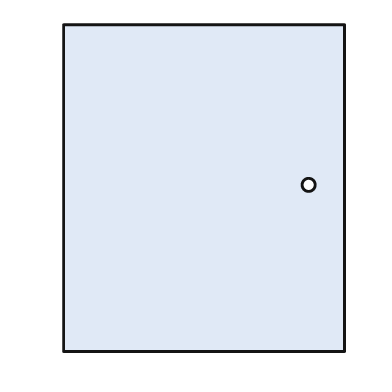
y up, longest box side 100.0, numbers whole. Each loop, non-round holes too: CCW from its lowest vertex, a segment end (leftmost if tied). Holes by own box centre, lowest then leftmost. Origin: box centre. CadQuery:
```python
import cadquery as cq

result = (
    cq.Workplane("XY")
    .moveTo(-43.0, -50.0)
    .lineTo(43.0, -50.0)
    .lineTo(43.0, 50.0)
    .lineTo(-43.0, 50.0)
    .close()
    .moveTo(32.0, 1.0)
    .circle(2.0)
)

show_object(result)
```